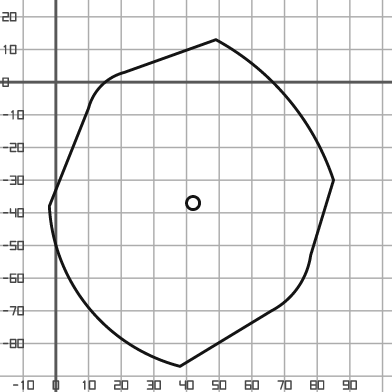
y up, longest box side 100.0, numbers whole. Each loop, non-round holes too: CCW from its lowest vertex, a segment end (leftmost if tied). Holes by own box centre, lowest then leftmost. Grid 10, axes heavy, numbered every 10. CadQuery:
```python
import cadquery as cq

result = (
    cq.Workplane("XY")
    .moveTo(38.0, -87.0)
    .lineTo(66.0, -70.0)
    .threePointArc((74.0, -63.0), (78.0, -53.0))
    .lineTo(85.0, -30.0)
    .threePointArc((71.0, -5.0), (49.0, 13.0))
    .lineTo(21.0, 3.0)
    .threePointArc((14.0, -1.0), (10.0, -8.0))
    .lineTo(-2.0, -38.0)
    .threePointArc((10.0, -69.0), (38.0, -87.0))
    .close()
    .moveTo(42.0, -37.0)
    .circle(2.0)
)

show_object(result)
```